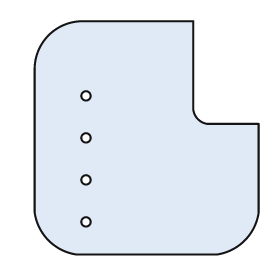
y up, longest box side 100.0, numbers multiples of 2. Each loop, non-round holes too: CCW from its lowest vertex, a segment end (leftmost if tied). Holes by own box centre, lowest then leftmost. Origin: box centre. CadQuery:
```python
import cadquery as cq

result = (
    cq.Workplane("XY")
    .moveTo(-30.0, -50.0)
    .lineTo(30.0, -50.0)
    .threePointArc((42.0, -44.0), (48.0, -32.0))
    .lineTo(48.0, 6.0)
    .lineTo(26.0, 6.0)
    .threePointArc((22.0, 8.0), (20.0, 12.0))
    .lineTo(20.0, 50.0)
    .lineTo(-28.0, 50.0)
    .threePointArc((-42.0, 44.0), (-48.0, 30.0))
    .lineTo(-48.0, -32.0)
    .threePointArc((-42.0, -44.0), (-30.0, -50.0))
    .close()
    .moveTo(-26.0, -36.0)
    .circle(2.0)
    .moveTo(-26.0, -18.0)
    .circle(2.0)
    .moveTo(-26.0, 0.0)
    .circle(2.0)
    .moveTo(-26.0, 18.0)
    .circle(2.0)
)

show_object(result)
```